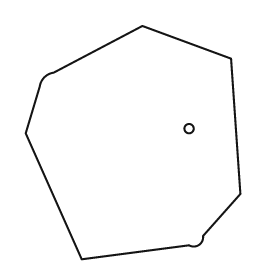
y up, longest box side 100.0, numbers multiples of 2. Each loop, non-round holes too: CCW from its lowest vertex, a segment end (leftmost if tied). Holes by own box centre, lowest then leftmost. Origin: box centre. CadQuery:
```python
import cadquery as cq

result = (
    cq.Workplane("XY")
    .moveTo(-22.0, -50.0)
    .lineTo(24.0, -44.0)
    .threePointArc((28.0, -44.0), (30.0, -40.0))
    .lineTo(46.0, -22.0)
    .lineTo(42.0, 36.0)
    .lineTo(4.0, 50.0)
    .lineTo(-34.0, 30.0)
    .threePointArc((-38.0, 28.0), (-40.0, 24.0))
    .lineTo(-46.0, 4.0)
    .close()
    .moveTo(24.0, 6.0)
    .circle(2.0)
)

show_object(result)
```